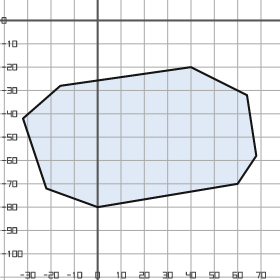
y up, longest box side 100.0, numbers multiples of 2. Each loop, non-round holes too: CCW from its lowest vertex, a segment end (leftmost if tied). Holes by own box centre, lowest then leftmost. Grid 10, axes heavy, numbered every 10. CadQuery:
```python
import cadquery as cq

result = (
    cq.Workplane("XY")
    .moveTo(0.0, -80.0)
    .lineTo(60.0, -70.0)
    .lineTo(68.0, -58.0)
    .lineTo(64.0, -32.0)
    .lineTo(40.0, -20.0)
    .lineTo(-16.0, -28.0)
    .lineTo(-32.0, -42.0)
    .lineTo(-22.0, -72.0)
    .close()
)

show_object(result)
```